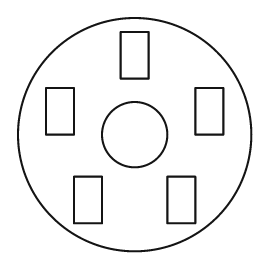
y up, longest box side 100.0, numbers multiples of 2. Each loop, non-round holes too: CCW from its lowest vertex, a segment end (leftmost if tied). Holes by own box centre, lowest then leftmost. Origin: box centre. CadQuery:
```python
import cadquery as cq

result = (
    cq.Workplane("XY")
    .moveTo(0.0, 0.0)
    .circle(50.0)
    .moveTo(-26.0, -38.0)
    .lineTo(-14.0, -38.0)
    .lineTo(-14.0, -18.0)
    .lineTo(-26.0, -18.0)
    .close()
    .moveTo(14.0, -38.0)
    .lineTo(26.0, -38.0)
    .lineTo(26.0, -18.0)
    .lineTo(14.0, -18.0)
    .close()
    .moveTo(0.0, 0.0)
    .circle(14.0)
    .moveTo(-38.0, 0.0)
    .lineTo(-26.0, 0.0)
    .lineTo(-26.0, 20.0)
    .lineTo(-38.0, 20.0)
    .close()
    .moveTo(26.0, 0.0)
    .lineTo(38.0, 0.0)
    .lineTo(38.0, 20.0)
    .lineTo(26.0, 20.0)
    .close()
    .moveTo(-6.0, 24.0)
    .lineTo(6.0, 24.0)
    .lineTo(6.0, 44.0)
    .lineTo(-6.0, 44.0)
    .close()
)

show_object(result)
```